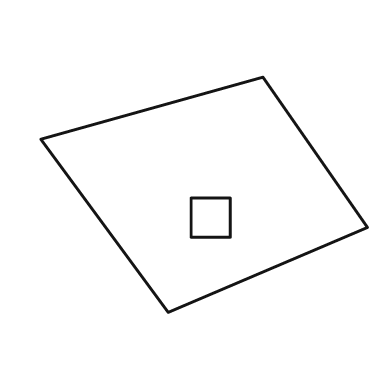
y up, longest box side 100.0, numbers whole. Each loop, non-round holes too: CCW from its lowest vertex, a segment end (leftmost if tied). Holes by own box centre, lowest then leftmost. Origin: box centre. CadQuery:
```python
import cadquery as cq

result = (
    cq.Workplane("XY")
    .moveTo(-11.0, -36.0)
    .lineTo(50.0, -10.0)
    .lineTo(18.0, 36.0)
    .lineTo(-50.0, 17.0)
    .close()
    .moveTo(-4.0, -13.0)
    .lineTo(8.0, -13.0)
    .lineTo(8.0, -1.0)
    .lineTo(-4.0, -1.0)
    .close()
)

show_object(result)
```